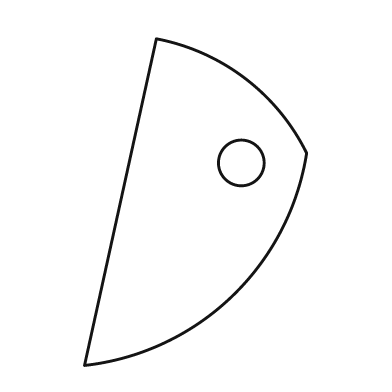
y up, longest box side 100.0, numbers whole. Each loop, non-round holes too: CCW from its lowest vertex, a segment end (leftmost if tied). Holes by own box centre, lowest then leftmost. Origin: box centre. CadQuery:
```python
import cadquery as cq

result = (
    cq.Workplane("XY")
    .moveTo(-34.0, -50.0)
    .threePointArc((11.0, -29.0), (34.0, 15.0))
    .threePointArc((15.0, 38.0), (-12.0, 50.0))
    .close()
    .moveTo(14.0, 12.0)
    .circle(7.0)
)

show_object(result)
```